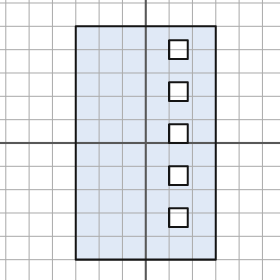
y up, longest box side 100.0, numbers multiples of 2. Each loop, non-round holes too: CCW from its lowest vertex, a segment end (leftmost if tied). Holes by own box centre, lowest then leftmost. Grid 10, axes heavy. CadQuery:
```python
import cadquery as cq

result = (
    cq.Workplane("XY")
    .moveTo(-30.0, -50.0)
    .lineTo(30.0, -50.0)
    .lineTo(30.0, 50.0)
    .lineTo(-30.0, 50.0)
    .close()
    .moveTo(10.0, -36.0)
    .lineTo(18.0, -36.0)
    .lineTo(18.0, -28.0)
    .lineTo(10.0, -28.0)
    .close()
    .moveTo(10.0, -18.0)
    .lineTo(18.0, -18.0)
    .lineTo(18.0, -10.0)
    .lineTo(10.0, -10.0)
    .close()
    .moveTo(10.0, 0.0)
    .lineTo(18.0, 0.0)
    .lineTo(18.0, 8.0)
    .lineTo(10.0, 8.0)
    .close()
    .moveTo(10.0, 18.0)
    .lineTo(18.0, 18.0)
    .lineTo(18.0, 26.0)
    .lineTo(10.0, 26.0)
    .close()
    .moveTo(10.0, 36.0)
    .lineTo(18.0, 36.0)
    .lineTo(18.0, 44.0)
    .lineTo(10.0, 44.0)
    .close()
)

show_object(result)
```